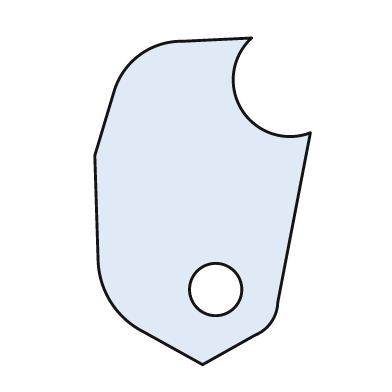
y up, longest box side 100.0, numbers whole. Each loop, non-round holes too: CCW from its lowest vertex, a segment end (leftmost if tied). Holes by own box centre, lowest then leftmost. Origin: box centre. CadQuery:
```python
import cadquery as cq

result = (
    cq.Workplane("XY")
    .moveTo(0.0, -50.0)
    .lineTo(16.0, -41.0)
    .threePointArc((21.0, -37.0), (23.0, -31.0))
    .lineTo(33.0, 21.0)
    .threePointArc((12.0, 28.0), (15.0, 50.0))
    .lineTo(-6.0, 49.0)
    .threePointArc((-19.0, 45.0), (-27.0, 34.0))
    .lineTo(-33.0, 14.0)
    .lineTo(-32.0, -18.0)
    .threePointArc((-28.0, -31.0), (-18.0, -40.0))
    .close()
    .moveTo(4.0, -27.0)
    .circle(8.0)
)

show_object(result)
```